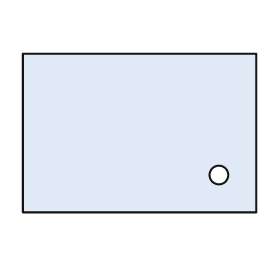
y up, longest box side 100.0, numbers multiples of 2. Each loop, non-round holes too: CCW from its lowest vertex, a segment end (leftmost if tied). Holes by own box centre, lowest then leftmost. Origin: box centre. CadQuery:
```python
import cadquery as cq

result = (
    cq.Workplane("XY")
    .moveTo(-50.0, -34.0)
    .lineTo(50.0, -34.0)
    .lineTo(50.0, 34.0)
    .lineTo(-50.0, 34.0)
    .close()
    .moveTo(34.0, -18.0)
    .circle(4.0)
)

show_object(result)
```